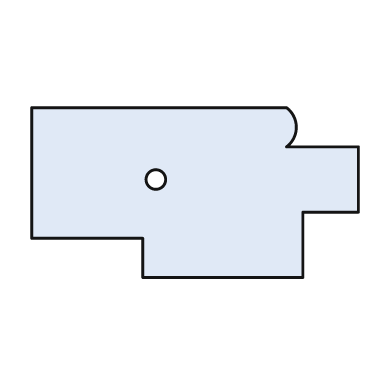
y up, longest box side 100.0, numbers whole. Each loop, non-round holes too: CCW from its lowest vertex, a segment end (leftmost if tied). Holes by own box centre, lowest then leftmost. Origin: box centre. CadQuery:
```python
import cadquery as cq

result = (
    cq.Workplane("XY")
    .moveTo(-16.0, -26.0)
    .lineTo(33.0, -26.0)
    .lineTo(33.0, -6.0)
    .lineTo(50.0, -6.0)
    .lineTo(50.0, 14.0)
    .lineTo(28.0, 14.0)
    .threePointArc((31.0, 20.0), (28.0, 26.0))
    .lineTo(-50.0, 26.0)
    .lineTo(-50.0, -14.0)
    .lineTo(-16.0, -14.0)
    .close()
    .moveTo(-12.0, 4.0)
    .circle(3.0)
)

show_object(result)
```